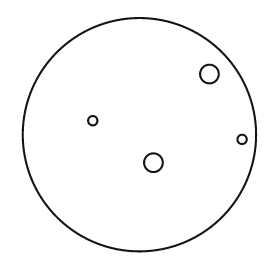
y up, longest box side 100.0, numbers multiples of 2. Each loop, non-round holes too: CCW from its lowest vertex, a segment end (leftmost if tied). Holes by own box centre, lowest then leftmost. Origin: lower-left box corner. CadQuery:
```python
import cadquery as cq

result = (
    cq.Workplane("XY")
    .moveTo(50.0, 50.0)
    .circle(50.0)
    .moveTo(56.0, 38.0)
    .circle(4.0)
    .moveTo(94.0, 48.0)
    .circle(2.0)
    .moveTo(30.0, 56.0)
    .circle(2.0)
    .moveTo(80.0, 76.0)
    .circle(4.0)
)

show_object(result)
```